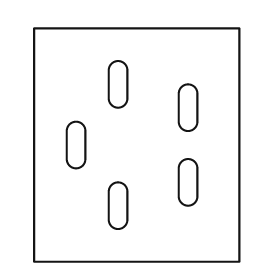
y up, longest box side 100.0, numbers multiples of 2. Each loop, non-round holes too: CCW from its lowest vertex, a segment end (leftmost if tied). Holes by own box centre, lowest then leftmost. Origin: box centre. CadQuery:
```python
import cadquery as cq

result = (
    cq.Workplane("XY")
    .moveTo(-44.0, -50.0)
    .lineTo(44.0, -50.0)
    .lineTo(44.0, 50.0)
    .lineTo(-44.0, 50.0)
    .close()
    .moveTo(-12.0, -32.0)
    .threePointArc((-8.0, -36.0), (-4.0, -32.0))
    .lineTo(-4.0, -20.0)
    .threePointArc((-8.0, -16.0), (-12.0, -20.0))
    .close()
    .moveTo(18.0, -22.0)
    .threePointArc((22.0, -26.0), (26.0, -22.0))
    .lineTo(26.0, -10.0)
    .threePointArc((22.0, -6.0), (18.0, -10.0))
    .close()
    .moveTo(-30.0, -6.0)
    .threePointArc((-26.0, -10.0), (-22.0, -6.0))
    .lineTo(-22.0, 6.0)
    .threePointArc((-26.0, 10.0), (-30.0, 6.0))
    .close()
    .moveTo(18.0, 10.0)
    .threePointArc((22.0, 6.0), (26.0, 10.0))
    .lineTo(26.0, 22.0)
    .threePointArc((22.0, 26.0), (18.0, 22.0))
    .close()
    .moveTo(-12.0, 20.0)
    .threePointArc((-8.0, 16.0), (-4.0, 20.0))
    .lineTo(-4.0, 32.0)
    .threePointArc((-8.0, 36.0), (-12.0, 32.0))
    .close()
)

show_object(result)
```